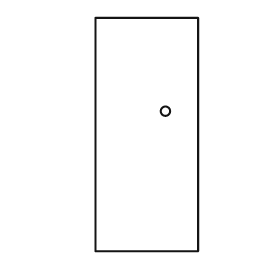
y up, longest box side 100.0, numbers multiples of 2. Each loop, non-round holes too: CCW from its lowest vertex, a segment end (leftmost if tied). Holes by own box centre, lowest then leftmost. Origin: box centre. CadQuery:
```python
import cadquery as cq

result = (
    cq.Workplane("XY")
    .moveTo(-22.0, -50.0)
    .lineTo(22.0, -50.0)
    .lineTo(22.0, 50.0)
    .lineTo(-22.0, 50.0)
    .close()
    .moveTo(8.0, 10.0)
    .circle(2.0)
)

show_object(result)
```